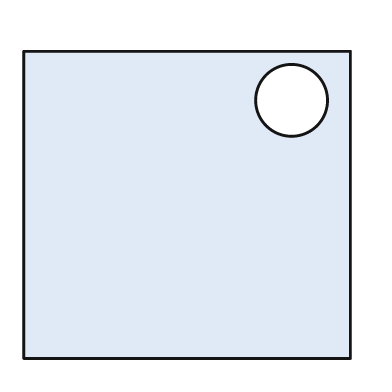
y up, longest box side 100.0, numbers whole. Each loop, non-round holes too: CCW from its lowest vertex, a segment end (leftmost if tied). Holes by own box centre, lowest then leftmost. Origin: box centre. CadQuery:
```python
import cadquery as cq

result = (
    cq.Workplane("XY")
    .moveTo(-50.0, -47.0)
    .lineTo(50.0, -47.0)
    .lineTo(50.0, 47.0)
    .lineTo(-50.0, 47.0)
    .close()
    .moveTo(32.0, 32.0)
    .circle(11.0)
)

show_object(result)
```